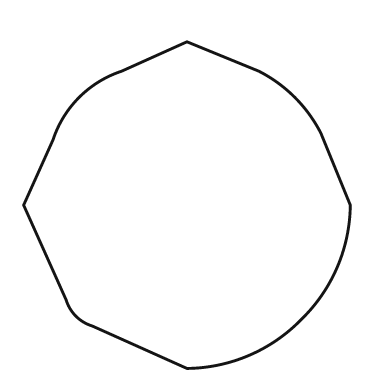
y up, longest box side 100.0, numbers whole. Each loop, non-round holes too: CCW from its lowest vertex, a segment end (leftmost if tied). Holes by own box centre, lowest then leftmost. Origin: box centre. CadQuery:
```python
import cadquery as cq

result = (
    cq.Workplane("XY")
    .moveTo(0.0, -50.0)
    .threePointArc((19.0, -46.0), (35.0, -35.0))
    .threePointArc((46.0, -19.0), (50.0, 0.0))
    .lineTo(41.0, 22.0)
    .threePointArc((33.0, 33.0), (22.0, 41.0))
    .lineTo(0.0, 50.0)
    .lineTo(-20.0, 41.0)
    .threePointArc((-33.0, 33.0), (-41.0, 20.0))
    .lineTo(-50.0, 0.0)
    .lineTo(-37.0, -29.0)
    .threePointArc((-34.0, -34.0), (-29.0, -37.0))
    .close()
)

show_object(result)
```